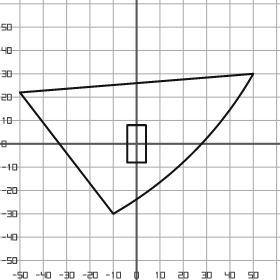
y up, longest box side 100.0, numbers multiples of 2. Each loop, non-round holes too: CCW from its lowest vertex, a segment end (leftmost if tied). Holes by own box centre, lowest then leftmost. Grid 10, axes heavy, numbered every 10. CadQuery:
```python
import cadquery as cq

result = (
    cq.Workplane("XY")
    .moveTo(-10.0, -30.0)
    .threePointArc((24.0, -4.0), (50.0, 30.0))
    .lineTo(-50.0, 22.0)
    .close()
    .moveTo(-4.0, -8.0)
    .lineTo(4.0, -8.0)
    .lineTo(4.0, 8.0)
    .lineTo(-4.0, 8.0)
    .close()
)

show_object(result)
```